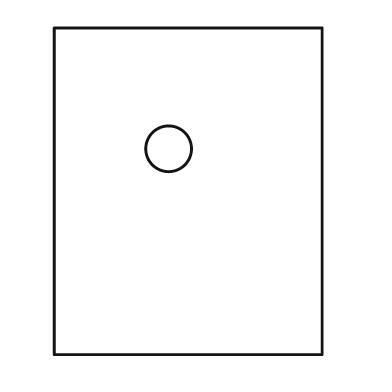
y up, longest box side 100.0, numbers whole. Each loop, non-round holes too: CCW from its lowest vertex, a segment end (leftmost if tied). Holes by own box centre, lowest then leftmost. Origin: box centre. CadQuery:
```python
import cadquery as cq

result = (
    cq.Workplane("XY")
    .moveTo(-41.0, -50.0)
    .lineTo(41.0, -50.0)
    .lineTo(41.0, 50.0)
    .lineTo(-41.0, 50.0)
    .close()
    .moveTo(-6.0, 13.0)
    .circle(7.0)
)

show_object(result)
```